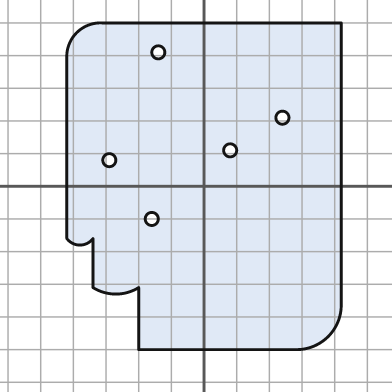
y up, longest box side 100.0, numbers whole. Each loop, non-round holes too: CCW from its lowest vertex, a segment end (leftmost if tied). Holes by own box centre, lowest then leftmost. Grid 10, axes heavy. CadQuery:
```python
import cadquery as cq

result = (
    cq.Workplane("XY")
    .moveTo(-20.0, -50.0)
    .lineTo(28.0, -50.0)
    .threePointArc((38.0, -46.0), (42.0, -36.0))
    .lineTo(42.0, 50.0)
    .lineTo(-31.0, 50.0)
    .threePointArc((-39.0, 47.0), (-42.0, 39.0))
    .lineTo(-42.0, -16.0)
    .threePointArc((-38.0, -18.0), (-34.0, -16.0))
    .lineTo(-34.0, -31.0)
    .threePointArc((-27.0, -33.0), (-20.0, -31.0))
    .close()
    .moveTo(-16.0, -10.0)
    .circle(2.0)
    .moveTo(-29.0, 8.0)
    .circle(2.0)
    .moveTo(8.0, 11.0)
    .circle(2.0)
    .moveTo(24.0, 21.0)
    .circle(2.0)
    .moveTo(-14.0, 41.0)
    .circle(2.0)
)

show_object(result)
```